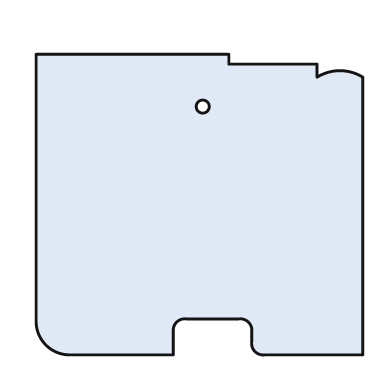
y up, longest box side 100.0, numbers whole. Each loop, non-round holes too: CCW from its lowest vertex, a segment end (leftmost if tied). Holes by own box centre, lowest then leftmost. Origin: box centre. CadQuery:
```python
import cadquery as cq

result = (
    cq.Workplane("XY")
    .moveTo(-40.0, -46.0)
    .lineTo(-8.0, -46.0)
    .lineTo(-8.0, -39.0)
    .threePointArc((-7.0, -36.0), (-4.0, -35.0))
    .lineTo(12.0, -35.0)
    .threePointArc((15.0, -36.0), (16.0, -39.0))
    .lineTo(16.0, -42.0)
    .threePointArc((17.0, -45.0), (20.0, -46.0))
    .lineTo(50.0, -46.0)
    .lineTo(50.0, 39.0)
    .threePointArc((43.0, 41.0), (36.0, 39.0))
    .lineTo(36.0, 43.0)
    .lineTo(9.0, 43.0)
    .lineTo(9.0, 46.0)
    .lineTo(-50.0, 46.0)
    .lineTo(-50.0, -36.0)
    .threePointArc((-47.0, -43.0), (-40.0, -46.0))
    .close()
    .moveTo(1.0, 30.0)
    .circle(2.0)
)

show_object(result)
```